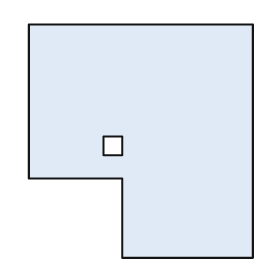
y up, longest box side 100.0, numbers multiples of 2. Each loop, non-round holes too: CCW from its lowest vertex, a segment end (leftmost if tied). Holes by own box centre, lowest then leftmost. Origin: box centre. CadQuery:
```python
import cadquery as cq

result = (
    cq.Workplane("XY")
    .moveTo(-8.0, -50.0)
    .lineTo(48.0, -50.0)
    .lineTo(48.0, 50.0)
    .lineTo(-48.0, 50.0)
    .lineTo(-48.0, -16.0)
    .lineTo(-8.0, -16.0)
    .close()
    .moveTo(-16.0, -6.0)
    .lineTo(-8.0, -6.0)
    .lineTo(-8.0, 2.0)
    .lineTo(-16.0, 2.0)
    .close()
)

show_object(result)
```